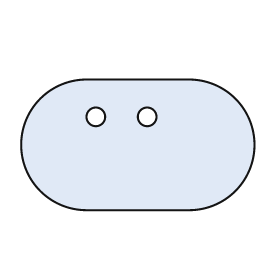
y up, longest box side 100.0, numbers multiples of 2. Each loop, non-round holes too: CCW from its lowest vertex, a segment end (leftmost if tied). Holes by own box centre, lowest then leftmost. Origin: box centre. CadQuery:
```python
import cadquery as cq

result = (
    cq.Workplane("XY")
    .moveTo(-22.0, -28.0)
    .lineTo(22.0, -28.0)
    .threePointArc((50.0, 0.0), (22.0, 28.0))
    .lineTo(-22.0, 28.0)
    .threePointArc((-50.0, 0.0), (-22.0, -28.0))
    .close()
    .moveTo(-18.0, 12.0)
    .circle(4.0)
    .moveTo(4.0, 12.0)
    .circle(4.0)
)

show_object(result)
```